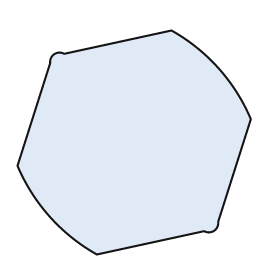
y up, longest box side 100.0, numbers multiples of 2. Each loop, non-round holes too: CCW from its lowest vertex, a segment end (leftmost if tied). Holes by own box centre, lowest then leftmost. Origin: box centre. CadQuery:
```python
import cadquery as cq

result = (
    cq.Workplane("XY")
    .moveTo(-16.0, -48.0)
    .lineTo(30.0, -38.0)
    .threePointArc((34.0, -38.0), (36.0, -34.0))
    .lineTo(50.0, 10.0)
    .threePointArc((36.0, 32.0), (16.0, 48.0))
    .lineTo(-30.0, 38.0)
    .threePointArc((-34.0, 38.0), (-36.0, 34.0))
    .lineTo(-50.0, -10.0)
    .threePointArc((-36.0, -32.0), (-16.0, -48.0))
    .close()
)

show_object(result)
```